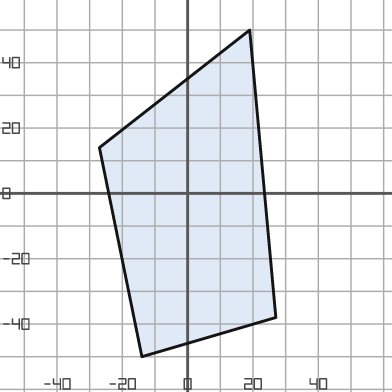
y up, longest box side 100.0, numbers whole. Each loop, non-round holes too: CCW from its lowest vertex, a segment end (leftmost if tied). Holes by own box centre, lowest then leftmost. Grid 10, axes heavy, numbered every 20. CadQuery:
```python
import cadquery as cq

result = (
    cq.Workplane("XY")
    .moveTo(-14.0, -50.0)
    .lineTo(27.0, -38.0)
    .lineTo(19.0, 50.0)
    .lineTo(-27.0, 14.0)
    .close()
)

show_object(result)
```